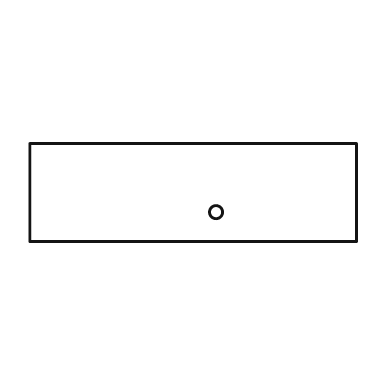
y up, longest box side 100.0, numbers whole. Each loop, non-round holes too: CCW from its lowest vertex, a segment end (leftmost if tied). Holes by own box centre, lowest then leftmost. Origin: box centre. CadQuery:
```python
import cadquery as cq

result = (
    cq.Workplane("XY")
    .moveTo(-50.0, -15.0)
    .lineTo(50.0, -15.0)
    .lineTo(50.0, 15.0)
    .lineTo(-50.0, 15.0)
    .close()
    .moveTo(7.0, -6.0)
    .circle(2.0)
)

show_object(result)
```